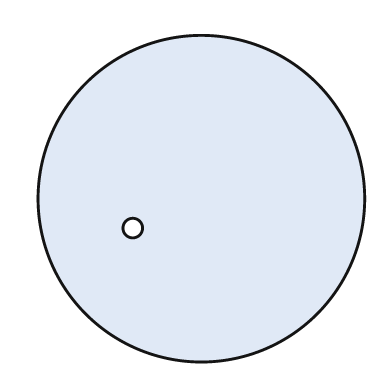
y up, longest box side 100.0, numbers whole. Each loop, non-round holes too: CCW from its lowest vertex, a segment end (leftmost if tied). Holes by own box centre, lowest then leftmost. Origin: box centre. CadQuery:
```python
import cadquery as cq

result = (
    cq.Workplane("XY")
    .moveTo(0.0, 0.0)
    .circle(50.0)
    .moveTo(-21.0, -9.0)
    .circle(3.0)
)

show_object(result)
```